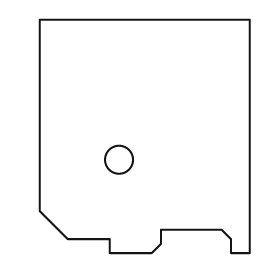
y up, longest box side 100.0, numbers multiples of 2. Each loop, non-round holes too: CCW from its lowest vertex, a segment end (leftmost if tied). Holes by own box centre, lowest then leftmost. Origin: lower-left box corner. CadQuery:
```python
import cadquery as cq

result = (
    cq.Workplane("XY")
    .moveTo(30.0, 0.0)
    .lineTo(48.0, 0.0)
    .lineTo(52.0, 4.0)
    .lineTo(52.0, 10.0)
    .lineTo(78.0, 10.0)
    .lineTo(82.0, 6.0)
    .lineTo(82.0, 0.0)
    .lineTo(90.0, 0.0)
    .lineTo(90.0, 100.0)
    .lineTo(0.0, 100.0)
    .lineTo(0.0, 18.0)
    .lineTo(12.0, 6.0)
    .lineTo(30.0, 6.0)
    .close()
    .moveTo(34.0, 40.0)
    .circle(6.0)
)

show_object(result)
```